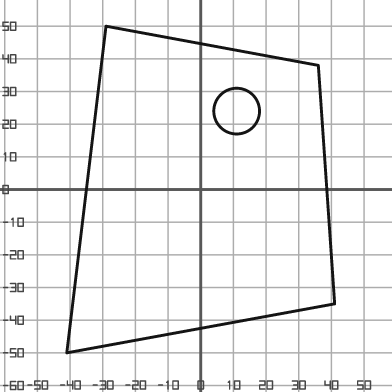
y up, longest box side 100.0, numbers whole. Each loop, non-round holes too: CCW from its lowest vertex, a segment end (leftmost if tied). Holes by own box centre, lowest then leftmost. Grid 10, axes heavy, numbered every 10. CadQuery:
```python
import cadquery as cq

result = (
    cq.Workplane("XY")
    .moveTo(-41.0, -50.0)
    .lineTo(41.0, -35.0)
    .lineTo(36.0, 38.0)
    .lineTo(-29.0, 50.0)
    .close()
    .moveTo(11.0, 24.0)
    .circle(7.0)
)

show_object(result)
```